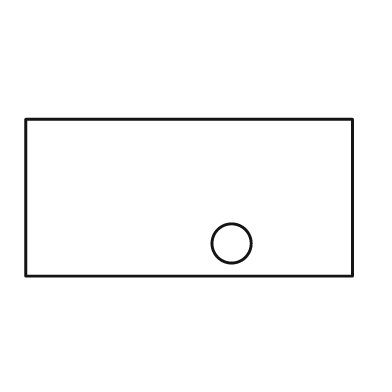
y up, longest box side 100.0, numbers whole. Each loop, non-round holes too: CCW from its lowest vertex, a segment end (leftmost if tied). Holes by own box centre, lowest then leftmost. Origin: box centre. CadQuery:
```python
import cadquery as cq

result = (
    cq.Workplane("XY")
    .moveTo(-50.0, -24.0)
    .lineTo(50.0, -24.0)
    .lineTo(50.0, 24.0)
    .lineTo(-50.0, 24.0)
    .close()
    .moveTo(13.0, -14.0)
    .circle(6.0)
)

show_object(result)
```